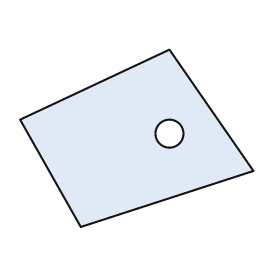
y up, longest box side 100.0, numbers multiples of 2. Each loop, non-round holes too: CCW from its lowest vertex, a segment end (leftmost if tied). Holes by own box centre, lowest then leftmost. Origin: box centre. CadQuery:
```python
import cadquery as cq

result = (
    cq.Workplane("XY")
    .moveTo(-24.0, -38.0)
    .lineTo(50.0, -14.0)
    .lineTo(14.0, 38.0)
    .lineTo(-50.0, 8.0)
    .close()
    .moveTo(14.0, 2.0)
    .circle(6.0)
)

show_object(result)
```